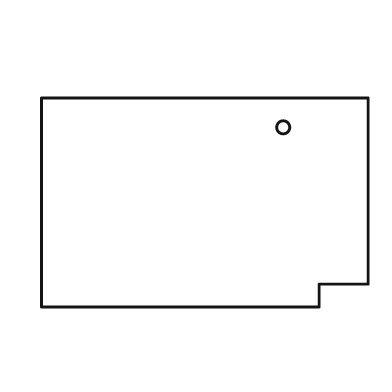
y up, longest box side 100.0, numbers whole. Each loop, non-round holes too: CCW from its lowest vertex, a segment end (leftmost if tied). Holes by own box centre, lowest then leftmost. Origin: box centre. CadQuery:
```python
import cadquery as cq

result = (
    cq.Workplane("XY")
    .moveTo(-50.0, -32.0)
    .lineTo(35.0, -32.0)
    .lineTo(35.0, -25.0)
    .lineTo(50.0, -25.0)
    .lineTo(50.0, 32.0)
    .lineTo(-50.0, 32.0)
    .close()
    .moveTo(24.0, 23.0)
    .circle(2.0)
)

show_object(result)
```